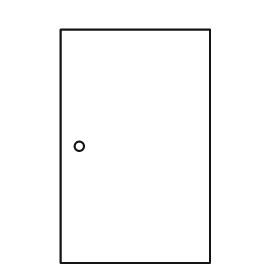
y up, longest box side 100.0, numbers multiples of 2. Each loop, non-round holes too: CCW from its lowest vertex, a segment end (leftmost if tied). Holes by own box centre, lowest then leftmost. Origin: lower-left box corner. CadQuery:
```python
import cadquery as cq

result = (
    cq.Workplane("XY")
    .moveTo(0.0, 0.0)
    .lineTo(64.0, 0.0)
    .lineTo(64.0, 100.0)
    .lineTo(0.0, 100.0)
    .close()
    .moveTo(8.0, 50.0)
    .circle(2.0)
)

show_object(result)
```